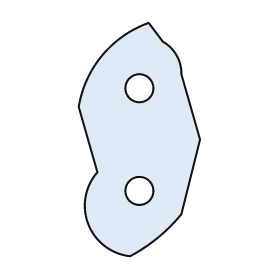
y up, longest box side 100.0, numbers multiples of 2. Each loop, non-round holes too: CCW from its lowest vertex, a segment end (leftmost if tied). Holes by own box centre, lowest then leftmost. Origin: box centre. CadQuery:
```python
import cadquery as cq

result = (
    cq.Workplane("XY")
    .moveTo(-4.0, -50.0)
    .threePointArc((8.0, -42.0), (18.0, -32.0))
    .lineTo(26.0, 0.0)
    .lineTo(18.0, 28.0)
    .threePointArc((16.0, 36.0), (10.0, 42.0))
    .lineTo(4.0, 50.0)
    .threePointArc((-16.0, 36.0), (-26.0, 14.0))
    .lineTo(-18.0, -14.0)
    .threePointArc((-22.0, -36.0), (-4.0, -50.0))
    .close()
    .moveTo(0.0, -22.0)
    .circle(6.0)
    .moveTo(0.0, 22.0)
    .circle(6.0)
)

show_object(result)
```